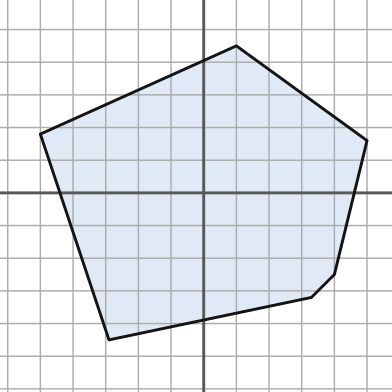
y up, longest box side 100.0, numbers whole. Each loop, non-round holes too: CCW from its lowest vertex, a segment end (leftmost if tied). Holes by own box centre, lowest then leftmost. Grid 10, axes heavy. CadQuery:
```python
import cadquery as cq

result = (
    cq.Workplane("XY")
    .moveTo(-29.0, -45.0)
    .lineTo(33.0, -32.0)
    .lineTo(40.0, -25.0)
    .lineTo(50.0, 16.0)
    .lineTo(10.0, 45.0)
    .lineTo(-50.0, 18.0)
    .close()
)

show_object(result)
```